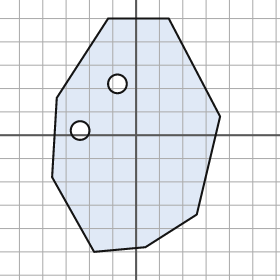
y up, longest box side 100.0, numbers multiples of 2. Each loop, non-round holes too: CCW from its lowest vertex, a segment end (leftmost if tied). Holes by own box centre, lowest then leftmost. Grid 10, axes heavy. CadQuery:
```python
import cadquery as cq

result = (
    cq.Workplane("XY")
    .moveTo(-18.0, -50.0)
    .lineTo(4.0, -48.0)
    .lineTo(26.0, -34.0)
    .lineTo(36.0, 8.0)
    .lineTo(14.0, 50.0)
    .lineTo(-12.0, 50.0)
    .lineTo(-34.0, 16.0)
    .lineTo(-36.0, -18.0)
    .close()
    .moveTo(-24.0, 2.0)
    .circle(4.0)
    .moveTo(-8.0, 22.0)
    .circle(4.0)
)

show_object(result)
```